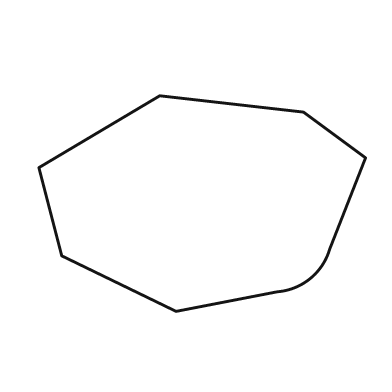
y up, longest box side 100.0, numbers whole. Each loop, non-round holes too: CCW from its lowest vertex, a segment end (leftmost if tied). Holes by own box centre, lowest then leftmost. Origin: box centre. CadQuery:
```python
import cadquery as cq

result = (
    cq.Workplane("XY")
    .moveTo(-8.0, -33.0)
    .lineTo(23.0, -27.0)
    .threePointArc((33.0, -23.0), (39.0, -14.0))
    .lineTo(50.0, 14.0)
    .lineTo(31.0, 28.0)
    .lineTo(-13.0, 33.0)
    .lineTo(-50.0, 11.0)
    .lineTo(-43.0, -16.0)
    .close()
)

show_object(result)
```